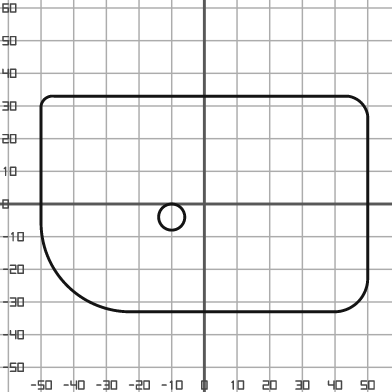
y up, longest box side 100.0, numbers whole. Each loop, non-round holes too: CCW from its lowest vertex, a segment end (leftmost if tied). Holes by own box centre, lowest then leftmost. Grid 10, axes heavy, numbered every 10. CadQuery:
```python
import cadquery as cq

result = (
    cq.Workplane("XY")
    .moveTo(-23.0, -33.0)
    .lineTo(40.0, -33.0)
    .threePointArc((47.0, -30.0), (50.0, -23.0))
    .lineTo(50.0, 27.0)
    .threePointArc((48.0, 31.0), (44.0, 33.0))
    .lineTo(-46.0, 33.0)
    .threePointArc((-49.0, 32.0), (-50.0, 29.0))
    .lineTo(-50.0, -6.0)
    .threePointArc((-42.0, -25.0), (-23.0, -33.0))
    .close()
    .moveTo(-10.0, -4.0)
    .circle(4.0)
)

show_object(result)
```